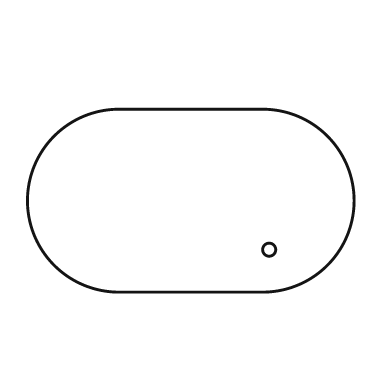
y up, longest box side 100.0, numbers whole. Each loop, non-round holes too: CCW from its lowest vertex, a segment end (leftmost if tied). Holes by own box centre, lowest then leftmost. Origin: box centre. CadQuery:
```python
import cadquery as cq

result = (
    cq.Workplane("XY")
    .moveTo(-22.0, -28.0)
    .lineTo(22.0, -28.0)
    .threePointArc((50.0, 0.0), (22.0, 28.0))
    .lineTo(-22.0, 28.0)
    .threePointArc((-50.0, 0.0), (-22.0, -28.0))
    .close()
    .moveTo(24.0, -15.0)
    .circle(2.0)
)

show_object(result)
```